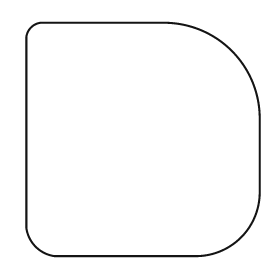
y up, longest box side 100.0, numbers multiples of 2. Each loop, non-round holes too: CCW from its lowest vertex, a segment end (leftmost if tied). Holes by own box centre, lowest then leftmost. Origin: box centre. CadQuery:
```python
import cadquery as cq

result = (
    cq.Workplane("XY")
    .moveTo(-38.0, -50.0)
    .lineTo(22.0, -50.0)
    .threePointArc((42.0, -42.0), (50.0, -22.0))
    .lineTo(50.0, 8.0)
    .threePointArc((38.0, 38.0), (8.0, 50.0))
    .lineTo(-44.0, 50.0)
    .threePointArc((-48.0, 48.0), (-50.0, 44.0))
    .lineTo(-50.0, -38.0)
    .threePointArc((-46.0, -46.0), (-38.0, -50.0))
    .close()
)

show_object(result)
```